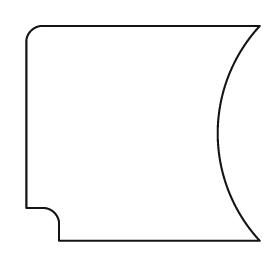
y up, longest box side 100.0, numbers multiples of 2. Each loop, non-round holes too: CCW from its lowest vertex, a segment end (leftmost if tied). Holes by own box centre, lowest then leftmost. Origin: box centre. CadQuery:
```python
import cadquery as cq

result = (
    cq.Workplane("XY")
    .moveTo(-36.0, -46.0)
    .lineTo(50.0, -46.0)
    .threePointArc((32.0, 0.0), (50.0, 46.0))
    .lineTo(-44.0, 46.0)
    .threePointArc((-48.0, 44.0), (-50.0, 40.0))
    .lineTo(-50.0, -32.0)
    .lineTo(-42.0, -32.0)
    .threePointArc((-38.0, -34.0), (-36.0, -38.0))
    .close()
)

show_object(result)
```